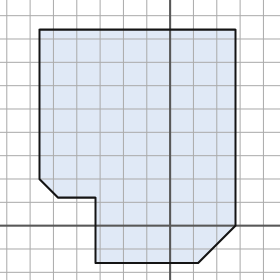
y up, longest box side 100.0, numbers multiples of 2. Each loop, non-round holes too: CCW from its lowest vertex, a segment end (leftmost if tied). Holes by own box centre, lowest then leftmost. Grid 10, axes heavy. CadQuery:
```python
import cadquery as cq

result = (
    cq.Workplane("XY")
    .moveTo(-32.0, -16.0)
    .lineTo(12.0, -16.0)
    .lineTo(28.0, 0.0)
    .lineTo(28.0, 84.0)
    .lineTo(-56.0, 84.0)
    .lineTo(-56.0, 20.0)
    .lineTo(-48.0, 12.0)
    .lineTo(-32.0, 12.0)
    .close()
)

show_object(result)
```